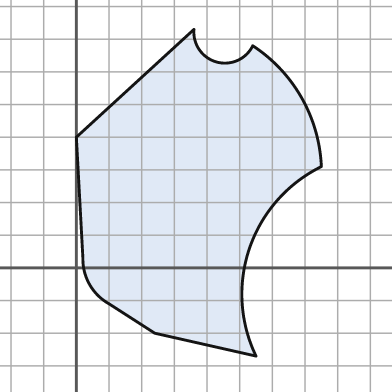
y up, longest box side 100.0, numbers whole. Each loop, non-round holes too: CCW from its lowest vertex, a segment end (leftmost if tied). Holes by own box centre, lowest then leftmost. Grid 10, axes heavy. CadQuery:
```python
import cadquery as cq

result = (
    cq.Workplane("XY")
    .moveTo(55.0, -27.0)
    .threePointArc((53.0, 6.0), (75.0, 31.0))
    .threePointArc((69.0, 52.0), (54.0, 68.0))
    .threePointArc((43.0, 63.0), (36.0, 73.0))
    .lineTo(0.0, 40.0)
    .lineTo(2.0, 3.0)
    .threePointArc((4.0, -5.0), (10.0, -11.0))
    .lineTo(24.0, -20.0)
    .close()
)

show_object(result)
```